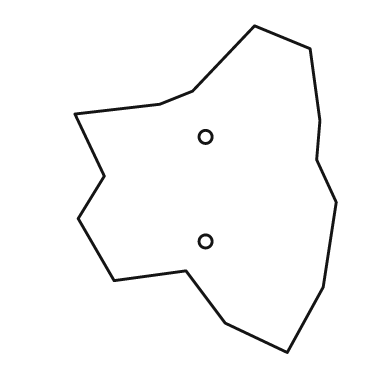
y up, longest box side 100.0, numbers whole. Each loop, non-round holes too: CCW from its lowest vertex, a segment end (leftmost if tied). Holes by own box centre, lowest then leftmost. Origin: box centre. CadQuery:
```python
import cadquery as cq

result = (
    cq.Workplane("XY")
    .moveTo(25.0, -50.0)
    .lineTo(36.0, -30.0)
    .lineTo(40.0, -4.0)
    .lineTo(34.0, 9.0)
    .lineTo(35.0, 21.0)
    .lineTo(32.0, 43.0)
    .lineTo(15.0, 50.0)
    .lineTo(-4.0, 30.0)
    .lineTo(-14.0, 26.0)
    .lineTo(-40.0, 23.0)
    .lineTo(-31.0, 4.0)
    .lineTo(-39.0, -9.0)
    .lineTo(-28.0, -28.0)
    .lineTo(-6.0, -25.0)
    .lineTo(6.0, -41.0)
    .close()
    .moveTo(0.0, -16.0)
    .circle(2.0)
    .moveTo(0.0, 16.0)
    .circle(2.0)
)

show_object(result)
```